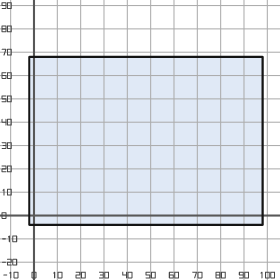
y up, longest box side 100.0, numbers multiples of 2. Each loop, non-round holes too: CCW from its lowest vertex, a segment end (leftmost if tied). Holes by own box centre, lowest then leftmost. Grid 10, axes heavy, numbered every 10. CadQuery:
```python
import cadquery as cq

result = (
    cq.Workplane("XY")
    .moveTo(-2.0, -4.0)
    .lineTo(98.0, -4.0)
    .lineTo(98.0, 68.0)
    .lineTo(-2.0, 68.0)
    .close()
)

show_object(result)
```